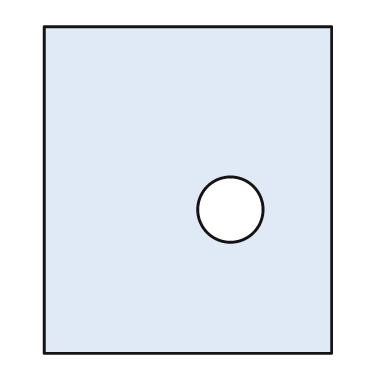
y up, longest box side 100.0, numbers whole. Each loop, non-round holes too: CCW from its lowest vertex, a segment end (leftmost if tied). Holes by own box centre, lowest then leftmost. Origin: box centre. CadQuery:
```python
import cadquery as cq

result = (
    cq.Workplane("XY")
    .moveTo(-44.0, -50.0)
    .lineTo(44.0, -50.0)
    .lineTo(44.0, 50.0)
    .lineTo(-44.0, 50.0)
    .close()
    .moveTo(13.0, -6.0)
    .circle(10.0)
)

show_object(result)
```